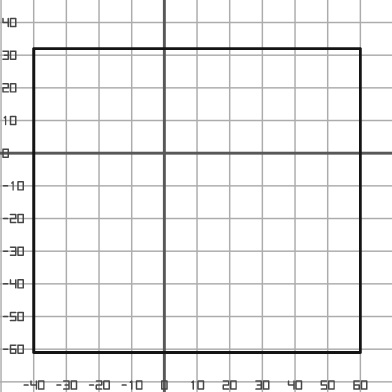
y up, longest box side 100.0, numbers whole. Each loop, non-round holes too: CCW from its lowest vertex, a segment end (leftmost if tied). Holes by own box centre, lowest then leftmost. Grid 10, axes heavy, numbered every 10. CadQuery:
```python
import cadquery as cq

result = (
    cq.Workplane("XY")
    .moveTo(-40.0, -61.0)
    .lineTo(60.0, -61.0)
    .lineTo(60.0, 32.0)
    .lineTo(-40.0, 32.0)
    .close()
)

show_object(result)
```